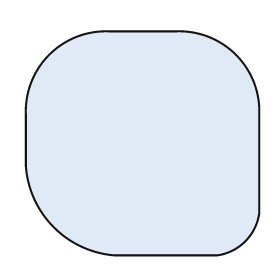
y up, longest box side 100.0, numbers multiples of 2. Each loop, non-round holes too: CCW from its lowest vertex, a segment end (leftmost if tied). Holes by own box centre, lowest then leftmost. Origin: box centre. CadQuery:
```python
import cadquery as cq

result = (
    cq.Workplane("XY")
    .moveTo(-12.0, -48.0)
    .lineTo(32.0, -48.0)
    .threePointArc((44.0, -42.0), (50.0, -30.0))
    .lineTo(50.0, 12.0)
    .threePointArc((40.0, 38.0), (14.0, 48.0))
    .lineTo(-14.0, 48.0)
    .threePointArc((-40.0, 38.0), (-50.0, 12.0))
    .lineTo(-50.0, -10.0)
    .threePointArc((-38.0, -36.0), (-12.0, -48.0))
    .close()
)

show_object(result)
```